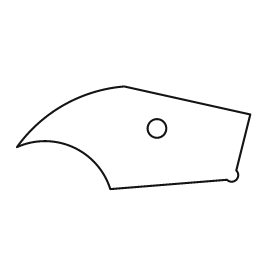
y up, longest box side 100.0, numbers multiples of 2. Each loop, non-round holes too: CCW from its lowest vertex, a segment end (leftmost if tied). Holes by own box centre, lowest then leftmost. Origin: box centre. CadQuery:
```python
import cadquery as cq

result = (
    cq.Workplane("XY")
    .moveTo(-10.0, -22.0)
    .lineTo(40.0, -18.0)
    .threePointArc((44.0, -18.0), (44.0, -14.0))
    .lineTo(50.0, 10.0)
    .lineTo(-4.0, 22.0)
    .threePointArc((-30.0, 14.0), (-50.0, -4.0))
    .threePointArc((-26.0, -4.0), (-10.0, -22.0))
    .close()
    .moveTo(10.0, 4.0)
    .circle(4.0)
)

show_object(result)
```